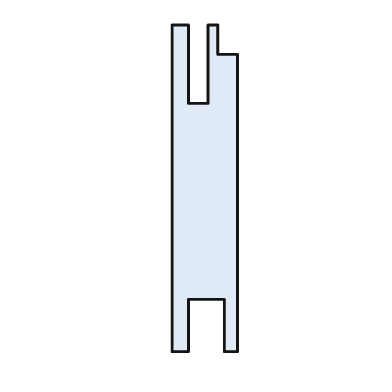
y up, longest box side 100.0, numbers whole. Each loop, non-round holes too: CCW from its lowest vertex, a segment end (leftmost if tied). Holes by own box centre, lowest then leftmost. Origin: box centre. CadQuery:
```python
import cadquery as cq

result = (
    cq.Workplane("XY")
    .moveTo(-10.0, -50.0)
    .lineTo(-5.0, -50.0)
    .lineTo(-5.0, -34.0)
    .lineTo(6.0, -34.0)
    .lineTo(6.0, -50.0)
    .lineTo(10.0, -50.0)
    .lineTo(10.0, 41.0)
    .lineTo(4.0, 41.0)
    .lineTo(4.0, 50.0)
    .lineTo(1.0, 50.0)
    .lineTo(1.0, 26.0)
    .lineTo(-5.0, 26.0)
    .lineTo(-5.0, 50.0)
    .lineTo(-10.0, 50.0)
    .close()
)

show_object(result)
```